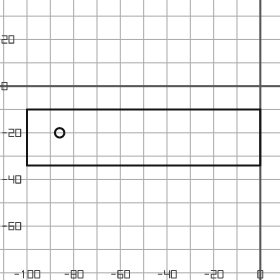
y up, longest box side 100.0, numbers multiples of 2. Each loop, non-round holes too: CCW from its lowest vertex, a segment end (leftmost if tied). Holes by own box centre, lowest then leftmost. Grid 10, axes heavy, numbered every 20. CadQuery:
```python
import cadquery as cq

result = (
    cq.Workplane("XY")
    .moveTo(-100.0, -34.0)
    .lineTo(0.0, -34.0)
    .lineTo(0.0, -10.0)
    .lineTo(-100.0, -10.0)
    .close()
    .moveTo(-86.0, -20.0)
    .circle(2.0)
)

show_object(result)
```